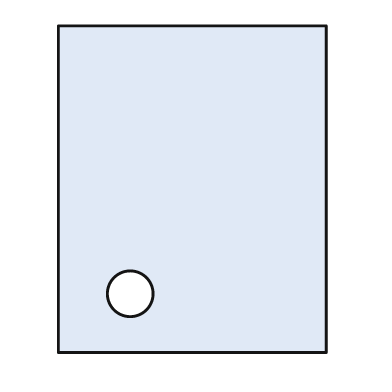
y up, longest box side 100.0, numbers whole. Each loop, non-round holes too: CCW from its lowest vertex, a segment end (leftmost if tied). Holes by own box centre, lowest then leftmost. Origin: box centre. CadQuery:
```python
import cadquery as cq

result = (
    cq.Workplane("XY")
    .moveTo(-41.0, -50.0)
    .lineTo(41.0, -50.0)
    .lineTo(41.0, 50.0)
    .lineTo(-41.0, 50.0)
    .close()
    .moveTo(-19.0, -32.0)
    .circle(7.0)
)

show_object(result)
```